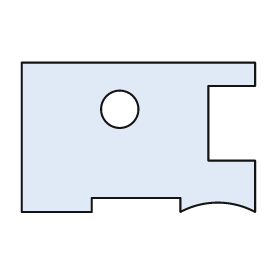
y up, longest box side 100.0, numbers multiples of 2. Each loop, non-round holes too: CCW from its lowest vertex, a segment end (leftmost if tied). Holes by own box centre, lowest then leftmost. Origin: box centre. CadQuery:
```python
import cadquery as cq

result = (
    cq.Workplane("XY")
    .moveTo(-50.0, -32.0)
    .lineTo(-20.0, -32.0)
    .lineTo(-20.0, -26.0)
    .lineTo(18.0, -26.0)
    .lineTo(18.0, -32.0)
    .threePointArc((34.0, -28.0), (50.0, -32.0))
    .lineTo(50.0, -10.0)
    .lineTo(30.0, -10.0)
    .lineTo(30.0, 22.0)
    .lineTo(50.0, 22.0)
    .lineTo(50.0, 32.0)
    .lineTo(-50.0, 32.0)
    .close()
    .moveTo(-8.0, 12.0)
    .circle(8.0)
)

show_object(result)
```